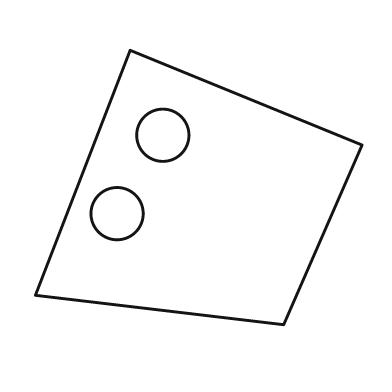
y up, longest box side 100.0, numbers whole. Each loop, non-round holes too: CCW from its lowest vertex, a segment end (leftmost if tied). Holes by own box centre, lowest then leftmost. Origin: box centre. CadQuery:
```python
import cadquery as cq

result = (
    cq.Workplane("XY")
    .moveTo(26.0, -42.0)
    .lineTo(50.0, 13.0)
    .lineTo(-21.0, 42.0)
    .lineTo(-50.0, -33.0)
    .close()
    .moveTo(-25.0, -8.0)
    .circle(8.0)
    .moveTo(-11.0, 16.0)
    .circle(8.0)
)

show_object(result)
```